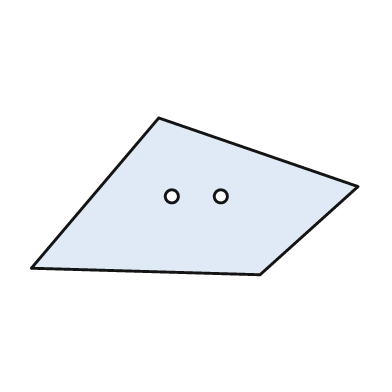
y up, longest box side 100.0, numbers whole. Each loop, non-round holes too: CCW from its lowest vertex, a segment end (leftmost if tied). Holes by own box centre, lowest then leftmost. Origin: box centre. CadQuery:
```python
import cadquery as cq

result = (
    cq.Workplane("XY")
    .moveTo(20.0, -24.0)
    .lineTo(50.0, 3.0)
    .lineTo(-11.0, 24.0)
    .lineTo(-50.0, -22.0)
    .close()
    .moveTo(-7.0, 0.0)
    .circle(2.0)
    .moveTo(8.0, 0.0)
    .circle(2.0)
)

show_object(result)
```